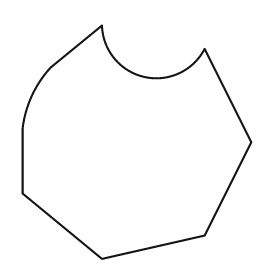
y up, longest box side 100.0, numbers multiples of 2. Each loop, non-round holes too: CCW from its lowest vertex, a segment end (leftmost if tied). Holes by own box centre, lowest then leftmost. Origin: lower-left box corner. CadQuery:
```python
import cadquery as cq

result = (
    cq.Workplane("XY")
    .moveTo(34.0, 0.0)
    .lineTo(78.0, 10.0)
    .lineTo(98.0, 50.0)
    .lineTo(78.0, 90.0)
    .threePointArc((52.0, 78.0), (34.0, 100.0))
    .lineTo(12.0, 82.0)
    .threePointArc((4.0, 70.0), (0.0, 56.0))
    .lineTo(0.0, 28.0)
    .close()
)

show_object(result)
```